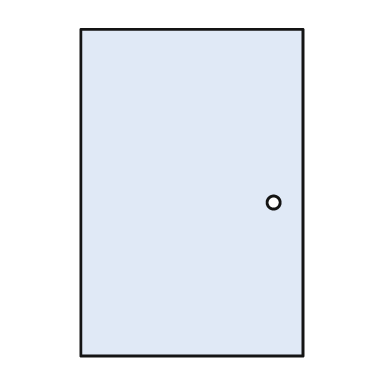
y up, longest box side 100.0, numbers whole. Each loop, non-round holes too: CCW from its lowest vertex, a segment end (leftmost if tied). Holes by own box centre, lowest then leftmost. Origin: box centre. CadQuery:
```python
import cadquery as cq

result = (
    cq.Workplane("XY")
    .moveTo(-34.0, -50.0)
    .lineTo(34.0, -50.0)
    .lineTo(34.0, 50.0)
    .lineTo(-34.0, 50.0)
    .close()
    .moveTo(25.0, -3.0)
    .circle(2.0)
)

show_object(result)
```